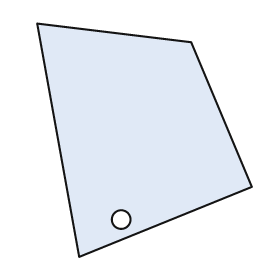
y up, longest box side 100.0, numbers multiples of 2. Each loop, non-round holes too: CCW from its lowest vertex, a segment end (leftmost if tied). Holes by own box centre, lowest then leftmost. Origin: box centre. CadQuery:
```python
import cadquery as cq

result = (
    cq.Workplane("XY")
    .moveTo(-28.0, -50.0)
    .lineTo(46.0, -20.0)
    .lineTo(20.0, 42.0)
    .lineTo(-46.0, 50.0)
    .close()
    .moveTo(-10.0, -34.0)
    .circle(4.0)
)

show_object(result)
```